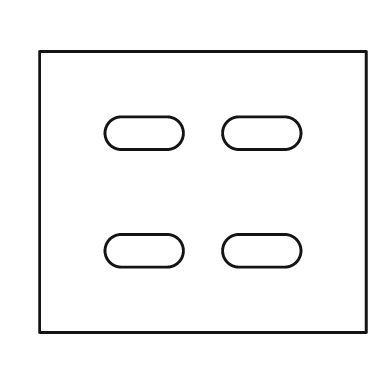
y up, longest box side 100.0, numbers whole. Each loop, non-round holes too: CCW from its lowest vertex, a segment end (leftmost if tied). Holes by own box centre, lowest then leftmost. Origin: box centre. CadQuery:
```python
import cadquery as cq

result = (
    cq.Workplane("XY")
    .moveTo(-50.0, -43.0)
    .lineTo(50.0, -43.0)
    .lineTo(50.0, 43.0)
    .lineTo(-50.0, 43.0)
    .close()
    .moveTo(-25.0, -23.0)
    .lineTo(-11.0, -23.0)
    .threePointArc((-6.0, -18.0), (-11.0, -13.0))
    .lineTo(-25.0, -13.0)
    .threePointArc((-30.0, -18.0), (-25.0, -23.0))
    .close()
    .moveTo(11.0, -23.0)
    .lineTo(25.0, -23.0)
    .threePointArc((30.0, -18.0), (25.0, -13.0))
    .lineTo(11.0, -13.0)
    .threePointArc((6.0, -18.0), (11.0, -23.0))
    .close()
    .moveTo(-25.0, 13.0)
    .lineTo(-11.0, 13.0)
    .threePointArc((-6.0, 18.0), (-11.0, 23.0))
    .lineTo(-25.0, 23.0)
    .threePointArc((-30.0, 18.0), (-25.0, 13.0))
    .close()
    .moveTo(11.0, 13.0)
    .lineTo(25.0, 13.0)
    .threePointArc((30.0, 18.0), (25.0, 23.0))
    .lineTo(11.0, 23.0)
    .threePointArc((6.0, 18.0), (11.0, 13.0))
    .close()
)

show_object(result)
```